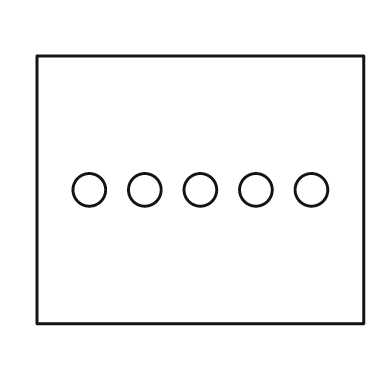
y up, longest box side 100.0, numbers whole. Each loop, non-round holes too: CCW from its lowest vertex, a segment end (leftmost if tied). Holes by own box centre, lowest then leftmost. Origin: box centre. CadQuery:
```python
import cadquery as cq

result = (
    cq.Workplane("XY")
    .moveTo(-50.0, -41.0)
    .lineTo(50.0, -41.0)
    .lineTo(50.0, 41.0)
    .lineTo(-50.0, 41.0)
    .close()
    .moveTo(-34.0, 0.0)
    .circle(5.0)
    .moveTo(-17.0, 0.0)
    .circle(5.0)
    .moveTo(0.0, 0.0)
    .circle(5.0)
    .moveTo(17.0, 0.0)
    .circle(5.0)
    .moveTo(34.0, 0.0)
    .circle(5.0)
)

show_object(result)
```